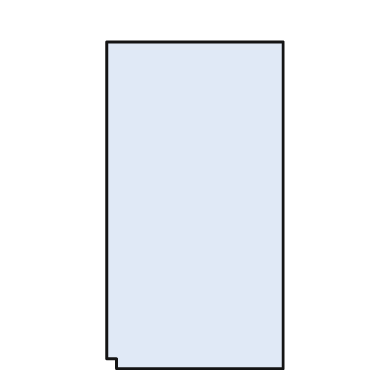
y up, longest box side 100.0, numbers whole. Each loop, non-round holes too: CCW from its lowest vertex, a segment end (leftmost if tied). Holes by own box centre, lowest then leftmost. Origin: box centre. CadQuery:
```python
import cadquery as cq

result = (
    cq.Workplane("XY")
    .moveTo(-24.0, -50.0)
    .lineTo(27.0, -50.0)
    .lineTo(27.0, 50.0)
    .lineTo(-27.0, 50.0)
    .lineTo(-27.0, -47.0)
    .lineTo(-24.0, -47.0)
    .close()
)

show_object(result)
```